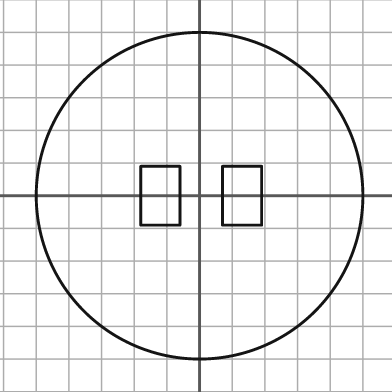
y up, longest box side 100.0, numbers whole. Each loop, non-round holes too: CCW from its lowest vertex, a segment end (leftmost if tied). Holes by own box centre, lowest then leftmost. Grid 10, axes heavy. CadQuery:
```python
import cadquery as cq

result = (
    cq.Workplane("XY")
    .moveTo(0.0, 0.0)
    .circle(50.0)
    .moveTo(-18.0, -9.0)
    .lineTo(-6.0, -9.0)
    .lineTo(-6.0, 9.0)
    .lineTo(-18.0, 9.0)
    .close()
    .moveTo(7.0, -9.0)
    .lineTo(19.0, -9.0)
    .lineTo(19.0, 9.0)
    .lineTo(7.0, 9.0)
    .close()
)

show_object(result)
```